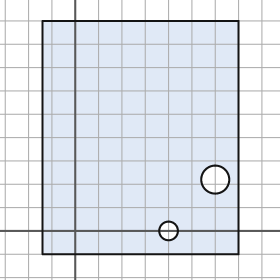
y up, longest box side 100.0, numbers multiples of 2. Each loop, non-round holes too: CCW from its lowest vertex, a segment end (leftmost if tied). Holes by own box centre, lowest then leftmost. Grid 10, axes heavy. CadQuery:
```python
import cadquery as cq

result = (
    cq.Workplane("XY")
    .moveTo(-14.0, -10.0)
    .lineTo(70.0, -10.0)
    .lineTo(70.0, 90.0)
    .lineTo(-14.0, 90.0)
    .close()
    .moveTo(40.0, 0.0)
    .circle(4.0)
    .moveTo(60.0, 22.0)
    .circle(6.0)
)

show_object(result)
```